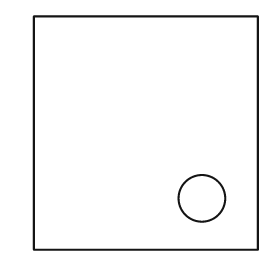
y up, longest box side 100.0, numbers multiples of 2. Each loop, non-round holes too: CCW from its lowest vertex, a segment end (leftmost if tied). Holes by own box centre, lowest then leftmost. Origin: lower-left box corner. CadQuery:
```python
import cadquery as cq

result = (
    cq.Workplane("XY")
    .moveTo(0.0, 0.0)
    .lineTo(96.0, 0.0)
    .lineTo(96.0, 100.0)
    .lineTo(0.0, 100.0)
    .close()
    .moveTo(72.0, 22.0)
    .circle(10.0)
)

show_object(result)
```